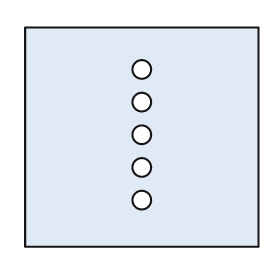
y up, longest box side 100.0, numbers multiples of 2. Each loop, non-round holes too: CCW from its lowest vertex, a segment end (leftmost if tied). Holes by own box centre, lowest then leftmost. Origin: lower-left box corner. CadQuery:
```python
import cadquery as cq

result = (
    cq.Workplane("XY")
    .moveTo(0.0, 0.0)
    .lineTo(100.0, 0.0)
    .lineTo(100.0, 94.0)
    .lineTo(0.0, 94.0)
    .close()
    .moveTo(50.0, 20.0)
    .circle(4.0)
    .moveTo(50.0, 34.0)
    .circle(4.0)
    .moveTo(50.0, 48.0)
    .circle(4.0)
    .moveTo(50.0, 62.0)
    .circle(4.0)
    .moveTo(50.0, 76.0)
    .circle(4.0)
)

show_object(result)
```